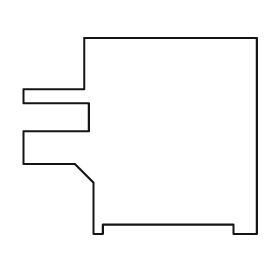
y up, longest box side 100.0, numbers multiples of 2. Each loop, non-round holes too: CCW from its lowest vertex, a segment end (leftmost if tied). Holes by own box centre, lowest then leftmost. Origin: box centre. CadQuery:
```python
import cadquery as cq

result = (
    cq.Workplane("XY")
    .moveTo(-20.0, -42.0)
    .lineTo(-16.0, -42.0)
    .lineTo(-16.0, -38.0)
    .lineTo(40.0, -38.0)
    .lineTo(40.0, -42.0)
    .lineTo(50.0, -42.0)
    .lineTo(50.0, 42.0)
    .lineTo(-24.0, 42.0)
    .lineTo(-24.0, 20.0)
    .lineTo(-50.0, 20.0)
    .lineTo(-50.0, 14.0)
    .lineTo(-22.0, 14.0)
    .lineTo(-22.0, 2.0)
    .lineTo(-50.0, 2.0)
    .lineTo(-50.0, -12.0)
    .lineTo(-28.0, -12.0)
    .lineTo(-20.0, -20.0)
    .close()
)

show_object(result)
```